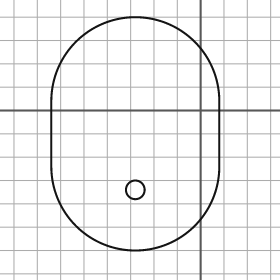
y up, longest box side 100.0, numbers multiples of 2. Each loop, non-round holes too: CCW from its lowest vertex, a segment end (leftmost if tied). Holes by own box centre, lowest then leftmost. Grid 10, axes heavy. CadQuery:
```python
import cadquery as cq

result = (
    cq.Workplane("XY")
    .moveTo(-64.0, -24.0)
    .threePointArc((-28.0, -60.0), (8.0, -24.0))
    .lineTo(8.0, 4.0)
    .threePointArc((-28.0, 40.0), (-64.0, 4.0))
    .close()
    .moveTo(-28.0, -34.0)
    .circle(4.0)
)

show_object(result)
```